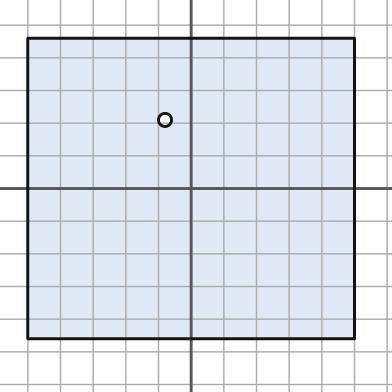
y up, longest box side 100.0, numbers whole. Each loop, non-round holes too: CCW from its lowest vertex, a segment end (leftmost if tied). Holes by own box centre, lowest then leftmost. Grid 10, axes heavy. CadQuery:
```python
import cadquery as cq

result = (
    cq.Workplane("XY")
    .moveTo(-50.0, -46.0)
    .lineTo(50.0, -46.0)
    .lineTo(50.0, 46.0)
    .lineTo(-50.0, 46.0)
    .close()
    .moveTo(-8.0, 21.0)
    .circle(2.0)
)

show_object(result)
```